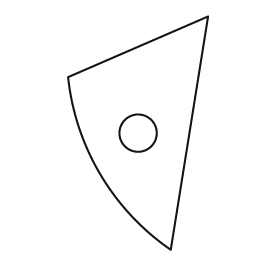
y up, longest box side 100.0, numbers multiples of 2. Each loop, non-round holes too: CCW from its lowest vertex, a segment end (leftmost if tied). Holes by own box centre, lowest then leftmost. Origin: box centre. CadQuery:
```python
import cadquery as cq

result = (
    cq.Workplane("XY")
    .moveTo(14.0, -50.0)
    .lineTo(30.0, 50.0)
    .lineTo(-30.0, 24.0)
    .threePointArc((-16.0, -18.0), (14.0, -50.0))
    .close()
    .moveTo(0.0, 0.0)
    .circle(8.0)
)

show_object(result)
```